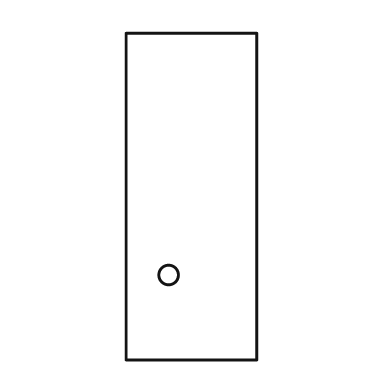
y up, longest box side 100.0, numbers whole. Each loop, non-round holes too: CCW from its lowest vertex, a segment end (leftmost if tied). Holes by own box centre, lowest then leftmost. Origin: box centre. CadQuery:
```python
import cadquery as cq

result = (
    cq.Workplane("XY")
    .moveTo(-20.0, -50.0)
    .lineTo(20.0, -50.0)
    .lineTo(20.0, 50.0)
    .lineTo(-20.0, 50.0)
    .close()
    .moveTo(-7.0, -24.0)
    .circle(3.0)
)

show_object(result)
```